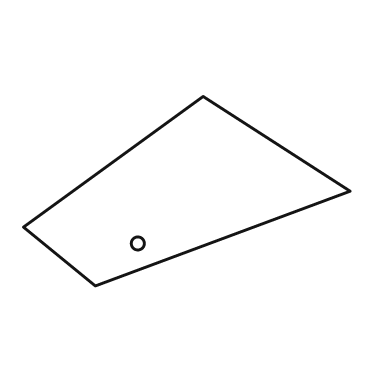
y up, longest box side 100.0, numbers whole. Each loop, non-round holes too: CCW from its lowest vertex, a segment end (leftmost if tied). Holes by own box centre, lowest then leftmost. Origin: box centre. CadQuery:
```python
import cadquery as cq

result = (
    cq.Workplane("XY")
    .moveTo(-28.0, -29.0)
    .lineTo(50.0, 0.0)
    .lineTo(5.0, 29.0)
    .lineTo(-50.0, -11.0)
    .close()
    .moveTo(-15.0, -16.0)
    .circle(2.0)
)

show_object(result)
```